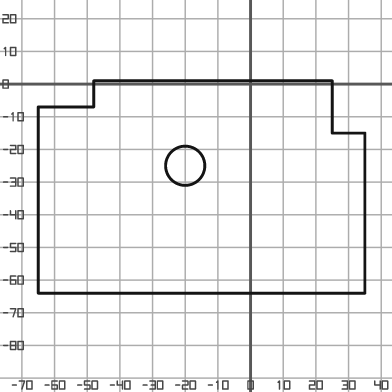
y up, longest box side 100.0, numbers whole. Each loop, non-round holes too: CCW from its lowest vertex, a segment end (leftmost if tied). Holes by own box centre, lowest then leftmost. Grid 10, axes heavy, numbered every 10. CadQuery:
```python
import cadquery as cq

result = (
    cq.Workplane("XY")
    .moveTo(-65.0, -64.0)
    .lineTo(35.0, -64.0)
    .lineTo(35.0, -15.0)
    .lineTo(25.0, -15.0)
    .lineTo(25.0, 1.0)
    .lineTo(-48.0, 1.0)
    .lineTo(-48.0, -7.0)
    .lineTo(-65.0, -7.0)
    .close()
    .moveTo(-20.0, -25.0)
    .circle(6.0)
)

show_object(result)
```